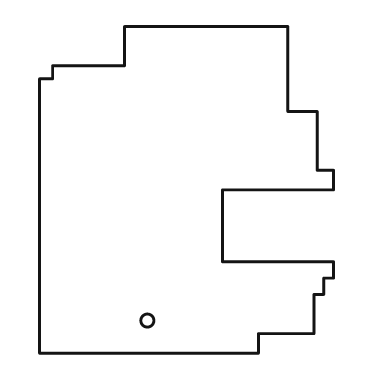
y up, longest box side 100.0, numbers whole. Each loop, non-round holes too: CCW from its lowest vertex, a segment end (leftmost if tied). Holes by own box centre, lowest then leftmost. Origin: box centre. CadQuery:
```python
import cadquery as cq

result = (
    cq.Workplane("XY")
    .moveTo(-45.0, -50.0)
    .lineTo(22.0, -50.0)
    .lineTo(22.0, -44.0)
    .lineTo(39.0, -44.0)
    .lineTo(39.0, -32.0)
    .lineTo(42.0, -32.0)
    .lineTo(42.0, -27.0)
    .lineTo(45.0, -27.0)
    .lineTo(45.0, -22.0)
    .lineTo(11.0, -22.0)
    .lineTo(11.0, 0.0)
    .lineTo(45.0, 0.0)
    .lineTo(45.0, 6.0)
    .lineTo(40.0, 6.0)
    .lineTo(40.0, 24.0)
    .lineTo(31.0, 24.0)
    .lineTo(31.0, 50.0)
    .lineTo(-19.0, 50.0)
    .lineTo(-19.0, 38.0)
    .lineTo(-41.0, 38.0)
    .lineTo(-41.0, 34.0)
    .lineTo(-45.0, 34.0)
    .close()
    .moveTo(-12.0, -40.0)
    .circle(2.0)
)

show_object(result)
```